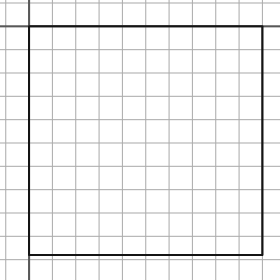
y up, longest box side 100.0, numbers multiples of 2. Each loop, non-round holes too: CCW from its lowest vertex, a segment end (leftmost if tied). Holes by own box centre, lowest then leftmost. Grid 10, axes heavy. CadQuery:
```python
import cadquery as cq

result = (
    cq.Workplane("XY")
    .moveTo(0.0, -98.0)
    .lineTo(100.0, -98.0)
    .lineTo(100.0, 0.0)
    .lineTo(0.0, 0.0)
    .close()
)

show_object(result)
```